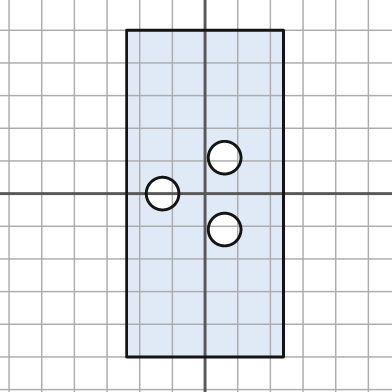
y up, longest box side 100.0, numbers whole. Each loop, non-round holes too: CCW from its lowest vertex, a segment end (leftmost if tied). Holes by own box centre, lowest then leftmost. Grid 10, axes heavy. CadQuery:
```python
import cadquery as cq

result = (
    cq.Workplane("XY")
    .moveTo(-24.0, -50.0)
    .lineTo(24.0, -50.0)
    .lineTo(24.0, 50.0)
    .lineTo(-24.0, 50.0)
    .close()
    .moveTo(6.0, -11.0)
    .circle(5.0)
    .moveTo(-13.0, 0.0)
    .circle(5.0)
    .moveTo(6.0, 11.0)
    .circle(5.0)
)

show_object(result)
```